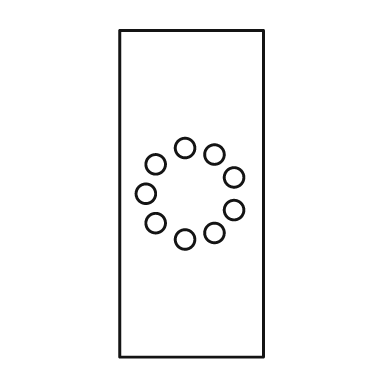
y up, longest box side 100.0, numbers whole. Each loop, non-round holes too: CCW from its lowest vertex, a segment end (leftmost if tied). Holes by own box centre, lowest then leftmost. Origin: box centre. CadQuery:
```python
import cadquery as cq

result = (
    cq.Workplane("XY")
    .moveTo(-22.0, -50.0)
    .lineTo(22.0, -50.0)
    .lineTo(22.0, 50.0)
    .lineTo(-22.0, 50.0)
    .close()
    .moveTo(-2.0, -14.0)
    .circle(3.0)
    .moveTo(7.0, -12.0)
    .circle(3.0)
    .moveTo(-11.0, -9.0)
    .circle(3.0)
    .moveTo(13.0, -5.0)
    .circle(3.0)
    .moveTo(-14.0, 0.0)
    .circle(3.0)
    .moveTo(13.0, 5.0)
    .circle(3.0)
    .moveTo(-11.0, 9.0)
    .circle(3.0)
    .moveTo(7.0, 12.0)
    .circle(3.0)
    .moveTo(-2.0, 14.0)
    .circle(3.0)
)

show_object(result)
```